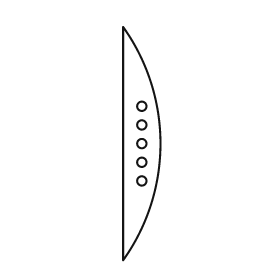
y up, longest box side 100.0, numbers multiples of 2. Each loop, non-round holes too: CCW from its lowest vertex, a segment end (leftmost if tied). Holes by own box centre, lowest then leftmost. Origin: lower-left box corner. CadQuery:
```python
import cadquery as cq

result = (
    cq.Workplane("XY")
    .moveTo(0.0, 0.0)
    .threePointArc((16.0, 50.0), (0.0, 100.0))
    .close()
    .moveTo(8.0, 34.0)
    .circle(2.0)
    .moveTo(8.0, 42.0)
    .circle(2.0)
    .moveTo(8.0, 50.0)
    .circle(2.0)
    .moveTo(8.0, 58.0)
    .circle(2.0)
    .moveTo(8.0, 66.0)
    .circle(2.0)
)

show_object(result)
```